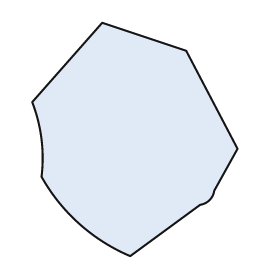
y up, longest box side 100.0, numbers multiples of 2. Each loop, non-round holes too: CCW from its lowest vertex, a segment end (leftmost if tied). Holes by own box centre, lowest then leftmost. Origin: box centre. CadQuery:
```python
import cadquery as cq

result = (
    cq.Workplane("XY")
    .moveTo(-2.0, -50.0)
    .lineTo(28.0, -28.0)
    .threePointArc((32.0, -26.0), (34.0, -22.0))
    .lineTo(44.0, -4.0)
    .lineTo(22.0, 38.0)
    .lineTo(-14.0, 50.0)
    .lineTo(-44.0, 16.0)
    .threePointArc((-40.0, 0.0), (-40.0, -16.0))
    .threePointArc((-24.0, -36.0), (-2.0, -50.0))
    .close()
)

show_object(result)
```